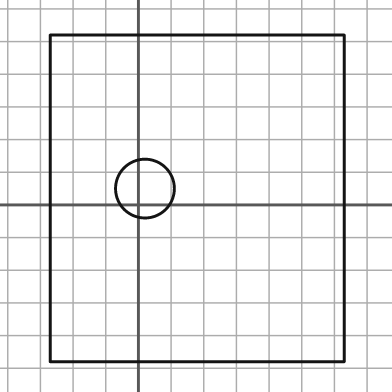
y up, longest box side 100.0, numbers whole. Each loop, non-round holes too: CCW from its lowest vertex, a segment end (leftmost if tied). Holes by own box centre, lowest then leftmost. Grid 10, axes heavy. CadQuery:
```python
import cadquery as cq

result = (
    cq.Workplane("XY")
    .moveTo(-27.0, -48.0)
    .lineTo(63.0, -48.0)
    .lineTo(63.0, 52.0)
    .lineTo(-27.0, 52.0)
    .close()
    .moveTo(2.0, 5.0)
    .circle(9.0)
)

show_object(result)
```